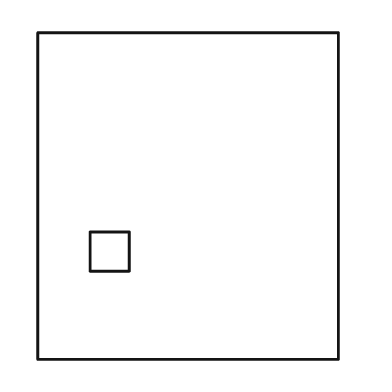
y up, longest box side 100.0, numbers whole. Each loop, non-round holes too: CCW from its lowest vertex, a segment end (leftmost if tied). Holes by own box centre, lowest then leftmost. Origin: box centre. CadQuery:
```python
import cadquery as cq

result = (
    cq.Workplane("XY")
    .moveTo(-46.0, -50.0)
    .lineTo(46.0, -50.0)
    .lineTo(46.0, 50.0)
    .lineTo(-46.0, 50.0)
    .close()
    .moveTo(-30.0, -23.0)
    .lineTo(-18.0, -23.0)
    .lineTo(-18.0, -11.0)
    .lineTo(-30.0, -11.0)
    .close()
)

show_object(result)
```